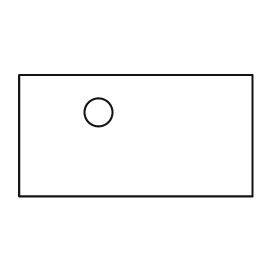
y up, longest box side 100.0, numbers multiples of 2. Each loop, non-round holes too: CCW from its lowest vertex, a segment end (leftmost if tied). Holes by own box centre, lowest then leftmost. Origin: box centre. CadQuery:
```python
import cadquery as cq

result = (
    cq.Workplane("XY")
    .moveTo(-50.0, -26.0)
    .lineTo(50.0, -26.0)
    .lineTo(50.0, 26.0)
    .lineTo(-50.0, 26.0)
    .close()
    .moveTo(-16.0, 10.0)
    .circle(6.0)
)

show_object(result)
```